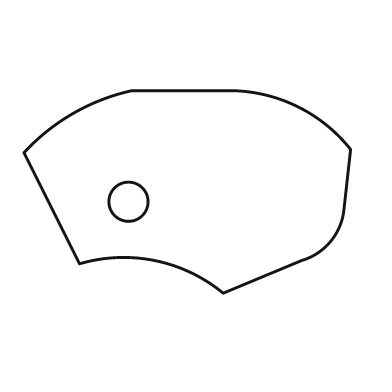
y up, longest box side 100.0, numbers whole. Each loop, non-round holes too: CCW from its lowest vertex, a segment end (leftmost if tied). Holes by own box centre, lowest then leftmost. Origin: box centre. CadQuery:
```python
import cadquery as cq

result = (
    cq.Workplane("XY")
    .moveTo(11.0, -31.0)
    .lineTo(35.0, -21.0)
    .threePointArc((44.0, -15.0), (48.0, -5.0))
    .lineTo(50.0, 13.0)
    .threePointArc((34.0, 26.0), (14.0, 31.0))
    .lineTo(-17.0, 31.0)
    .threePointArc((-35.0, 24.0), (-50.0, 12.0))
    .lineTo(-33.0, -22.0)
    .threePointArc((-10.0, -21.0), (11.0, -31.0))
    .close()
    .moveTo(-18.0, -3.0)
    .circle(6.0)
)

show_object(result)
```